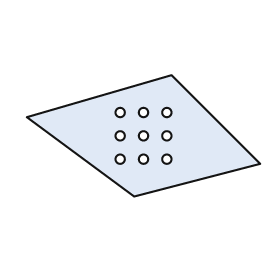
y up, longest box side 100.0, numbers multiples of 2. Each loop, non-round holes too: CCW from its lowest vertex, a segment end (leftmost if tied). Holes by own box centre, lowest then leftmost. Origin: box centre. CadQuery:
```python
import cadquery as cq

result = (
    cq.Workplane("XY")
    .moveTo(-4.0, -26.0)
    .lineTo(50.0, -12.0)
    .lineTo(12.0, 26.0)
    .lineTo(-50.0, 8.0)
    .close()
    .moveTo(-10.0, -10.0)
    .circle(2.0)
    .moveTo(0.0, -10.0)
    .circle(2.0)
    .moveTo(10.0, -10.0)
    .circle(2.0)
    .moveTo(-10.0, 0.0)
    .circle(2.0)
    .moveTo(0.0, 0.0)
    .circle(2.0)
    .moveTo(10.0, 0.0)
    .circle(2.0)
    .moveTo(-10.0, 10.0)
    .circle(2.0)
    .moveTo(0.0, 10.0)
    .circle(2.0)
    .moveTo(10.0, 10.0)
    .circle(2.0)
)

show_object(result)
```